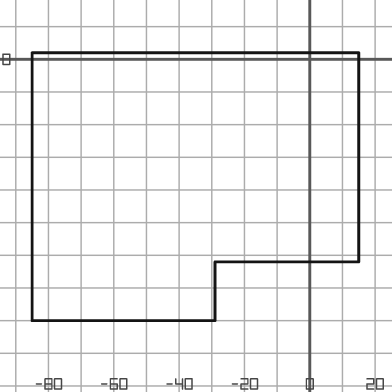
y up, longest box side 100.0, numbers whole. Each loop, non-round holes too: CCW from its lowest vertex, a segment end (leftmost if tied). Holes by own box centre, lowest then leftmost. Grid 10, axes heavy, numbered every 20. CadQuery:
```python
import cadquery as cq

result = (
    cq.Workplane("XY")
    .moveTo(-85.0, -80.0)
    .lineTo(-29.0, -80.0)
    .lineTo(-29.0, -62.0)
    .lineTo(15.0, -62.0)
    .lineTo(15.0, 2.0)
    .lineTo(-85.0, 2.0)
    .close()
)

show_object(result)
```